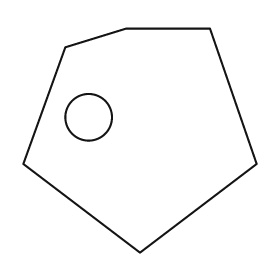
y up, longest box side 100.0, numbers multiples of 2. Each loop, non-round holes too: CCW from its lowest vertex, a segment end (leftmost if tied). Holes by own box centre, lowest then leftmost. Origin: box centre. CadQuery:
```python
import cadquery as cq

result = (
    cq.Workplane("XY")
    .moveTo(0.0, -48.0)
    .lineTo(50.0, -10.0)
    .lineTo(30.0, 48.0)
    .lineTo(-6.0, 48.0)
    .lineTo(-32.0, 40.0)
    .lineTo(-50.0, -10.0)
    .close()
    .moveTo(-22.0, 10.0)
    .circle(10.0)
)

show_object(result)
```